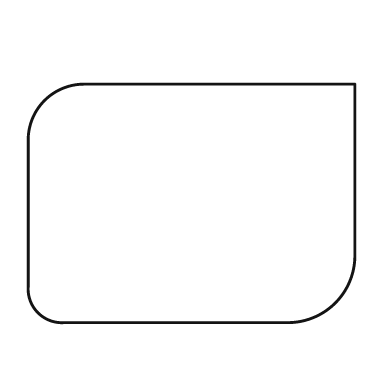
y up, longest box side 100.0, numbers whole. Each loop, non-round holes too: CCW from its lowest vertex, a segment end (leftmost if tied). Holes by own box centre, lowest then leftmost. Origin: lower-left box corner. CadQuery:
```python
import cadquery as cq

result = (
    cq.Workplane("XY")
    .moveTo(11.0, 0.0)
    .lineTo(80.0, 0.0)
    .threePointArc((94.0, 6.0), (100.0, 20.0))
    .lineTo(100.0, 73.0)
    .lineTo(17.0, 73.0)
    .threePointArc((5.0, 68.0), (0.0, 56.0))
    .lineTo(0.0, 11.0)
    .threePointArc((3.0, 3.0), (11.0, 0.0))
    .close()
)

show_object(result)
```